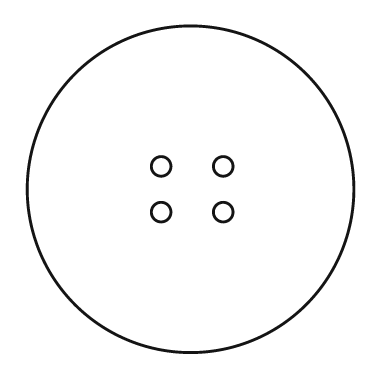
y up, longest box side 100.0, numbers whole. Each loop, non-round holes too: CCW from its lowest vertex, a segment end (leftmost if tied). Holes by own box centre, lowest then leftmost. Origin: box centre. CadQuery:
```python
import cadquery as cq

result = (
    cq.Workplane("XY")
    .moveTo(0.0, 0.0)
    .circle(50.0)
    .moveTo(-9.0, -7.0)
    .circle(3.0)
    .moveTo(10.0, -7.0)
    .circle(3.0)
    .moveTo(-9.0, 7.0)
    .circle(3.0)
    .moveTo(10.0, 7.0)
    .circle(3.0)
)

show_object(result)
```